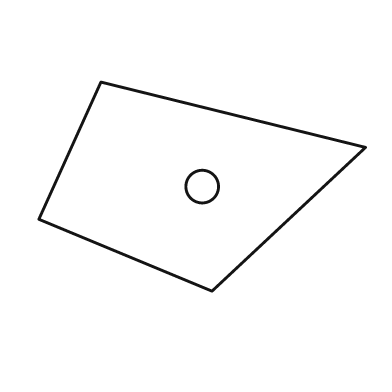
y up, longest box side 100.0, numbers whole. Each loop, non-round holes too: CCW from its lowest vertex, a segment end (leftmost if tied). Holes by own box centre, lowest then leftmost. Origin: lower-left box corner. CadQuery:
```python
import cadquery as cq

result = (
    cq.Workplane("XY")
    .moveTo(53.0, 0.0)
    .lineTo(100.0, 44.0)
    .lineTo(19.0, 64.0)
    .lineTo(0.0, 22.0)
    .close()
    .moveTo(50.0, 32.0)
    .circle(5.0)
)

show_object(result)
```